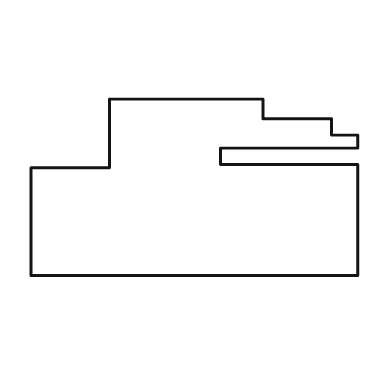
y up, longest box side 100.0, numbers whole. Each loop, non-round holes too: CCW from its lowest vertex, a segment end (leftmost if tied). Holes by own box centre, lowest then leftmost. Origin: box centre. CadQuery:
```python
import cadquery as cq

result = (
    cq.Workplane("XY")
    .moveTo(-50.0, -27.0)
    .lineTo(50.0, -27.0)
    .lineTo(50.0, 7.0)
    .lineTo(8.0, 7.0)
    .lineTo(8.0, 12.0)
    .lineTo(50.0, 12.0)
    .lineTo(50.0, 16.0)
    .lineTo(42.0, 16.0)
    .lineTo(42.0, 21.0)
    .lineTo(21.0, 21.0)
    .lineTo(21.0, 27.0)
    .lineTo(-26.0, 27.0)
    .lineTo(-26.0, 6.0)
    .lineTo(-50.0, 6.0)
    .close()
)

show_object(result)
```